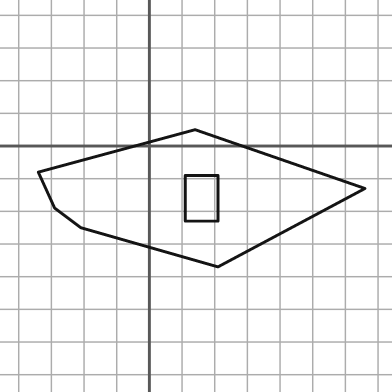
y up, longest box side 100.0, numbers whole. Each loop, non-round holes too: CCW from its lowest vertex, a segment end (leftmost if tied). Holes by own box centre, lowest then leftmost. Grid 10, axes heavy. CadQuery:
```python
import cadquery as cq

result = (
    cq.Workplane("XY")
    .moveTo(21.0, -37.0)
    .lineTo(66.0, -13.0)
    .lineTo(14.0, 5.0)
    .lineTo(-34.0, -8.0)
    .lineTo(-29.0, -19.0)
    .lineTo(-21.0, -25.0)
    .close()
    .moveTo(11.0, -23.0)
    .lineTo(21.0, -23.0)
    .lineTo(21.0, -9.0)
    .lineTo(11.0, -9.0)
    .close()
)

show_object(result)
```